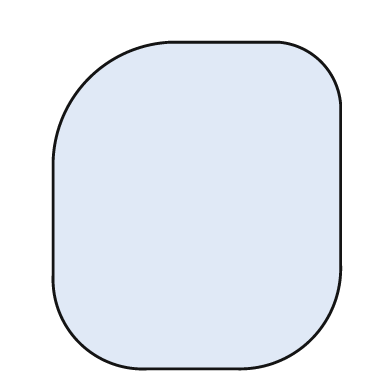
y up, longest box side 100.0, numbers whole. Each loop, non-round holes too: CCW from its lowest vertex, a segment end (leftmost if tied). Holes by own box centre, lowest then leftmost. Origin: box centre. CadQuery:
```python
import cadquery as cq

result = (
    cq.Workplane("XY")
    .moveTo(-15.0, -50.0)
    .lineTo(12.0, -50.0)
    .threePointArc((35.0, -41.0), (44.0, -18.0))
    .lineTo(44.0, 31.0)
    .threePointArc((38.0, 44.0), (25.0, 50.0))
    .lineTo(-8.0, 50.0)
    .threePointArc((-33.0, 39.0), (-44.0, 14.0))
    .lineTo(-44.0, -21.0)
    .threePointArc((-36.0, -42.0), (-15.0, -50.0))
    .close()
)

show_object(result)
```